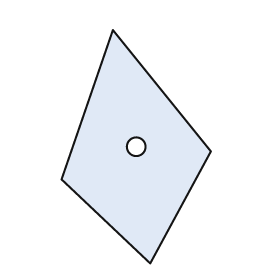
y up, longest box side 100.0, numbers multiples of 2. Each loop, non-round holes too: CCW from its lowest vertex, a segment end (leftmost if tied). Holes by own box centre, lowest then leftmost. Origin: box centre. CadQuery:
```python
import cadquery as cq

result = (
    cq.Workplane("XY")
    .moveTo(6.0, -50.0)
    .lineTo(32.0, -2.0)
    .lineTo(-10.0, 50.0)
    .lineTo(-32.0, -14.0)
    .close()
    .moveTo(0.0, 0.0)
    .circle(4.0)
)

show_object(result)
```